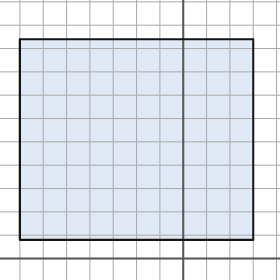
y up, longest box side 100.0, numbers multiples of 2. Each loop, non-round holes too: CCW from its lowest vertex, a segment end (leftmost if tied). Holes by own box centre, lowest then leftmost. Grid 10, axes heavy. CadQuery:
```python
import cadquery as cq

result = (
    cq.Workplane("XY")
    .moveTo(-70.0, 8.0)
    .lineTo(30.0, 8.0)
    .lineTo(30.0, 94.0)
    .lineTo(-70.0, 94.0)
    .close()
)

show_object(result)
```